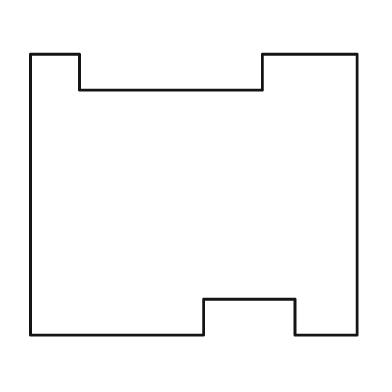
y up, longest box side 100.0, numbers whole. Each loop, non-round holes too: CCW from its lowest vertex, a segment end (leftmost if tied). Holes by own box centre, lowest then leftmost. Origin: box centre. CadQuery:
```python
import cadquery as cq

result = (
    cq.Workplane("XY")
    .moveTo(-50.0, -43.0)
    .lineTo(3.0, -43.0)
    .lineTo(3.0, -32.0)
    .lineTo(31.0, -32.0)
    .lineTo(31.0, -43.0)
    .lineTo(50.0, -43.0)
    .lineTo(50.0, 43.0)
    .lineTo(21.0, 43.0)
    .lineTo(21.0, 32.0)
    .lineTo(-35.0, 32.0)
    .lineTo(-35.0, 43.0)
    .lineTo(-50.0, 43.0)
    .close()
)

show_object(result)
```